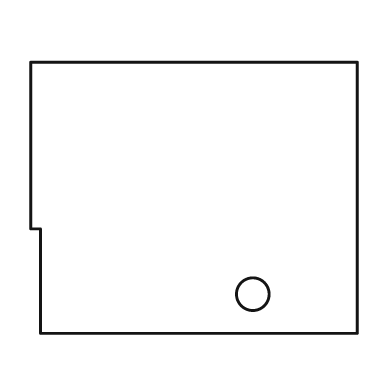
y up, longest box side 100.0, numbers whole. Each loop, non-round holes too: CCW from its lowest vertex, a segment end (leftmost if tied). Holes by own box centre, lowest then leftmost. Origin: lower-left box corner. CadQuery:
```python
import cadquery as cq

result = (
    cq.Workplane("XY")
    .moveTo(3.0, 0.0)
    .lineTo(100.0, 0.0)
    .lineTo(100.0, 83.0)
    .lineTo(0.0, 83.0)
    .lineTo(0.0, 32.0)
    .lineTo(3.0, 32.0)
    .close()
    .moveTo(68.0, 12.0)
    .circle(5.0)
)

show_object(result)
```